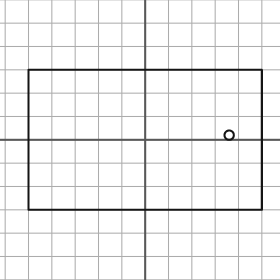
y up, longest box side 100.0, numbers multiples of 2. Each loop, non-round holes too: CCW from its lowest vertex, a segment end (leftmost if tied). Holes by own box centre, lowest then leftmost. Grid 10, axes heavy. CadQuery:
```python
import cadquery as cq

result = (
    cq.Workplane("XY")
    .moveTo(-50.0, -30.0)
    .lineTo(50.0, -30.0)
    .lineTo(50.0, 30.0)
    .lineTo(-50.0, 30.0)
    .close()
    .moveTo(36.0, 2.0)
    .circle(2.0)
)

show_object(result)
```